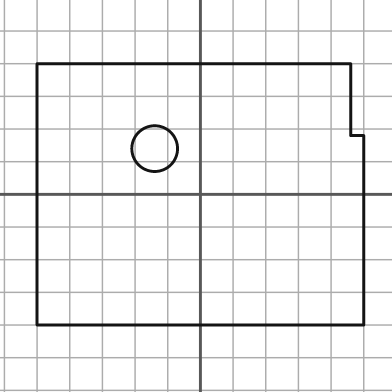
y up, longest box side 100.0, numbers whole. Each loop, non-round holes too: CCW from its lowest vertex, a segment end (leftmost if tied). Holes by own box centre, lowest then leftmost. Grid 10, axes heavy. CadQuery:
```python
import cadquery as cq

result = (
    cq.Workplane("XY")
    .moveTo(-50.0, -40.0)
    .lineTo(50.0, -40.0)
    .lineTo(50.0, 18.0)
    .lineTo(46.0, 18.0)
    .lineTo(46.0, 40.0)
    .lineTo(-50.0, 40.0)
    .close()
    .moveTo(-14.0, 14.0)
    .circle(7.0)
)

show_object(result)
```